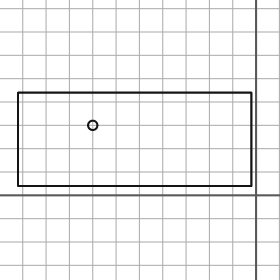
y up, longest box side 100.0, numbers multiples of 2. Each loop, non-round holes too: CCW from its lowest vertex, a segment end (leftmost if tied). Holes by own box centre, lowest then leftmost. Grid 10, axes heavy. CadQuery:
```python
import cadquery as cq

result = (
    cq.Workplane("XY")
    .moveTo(-102.0, 4.0)
    .lineTo(-2.0, 4.0)
    .lineTo(-2.0, 44.0)
    .lineTo(-102.0, 44.0)
    .close()
    .moveTo(-70.0, 30.0)
    .circle(2.0)
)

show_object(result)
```